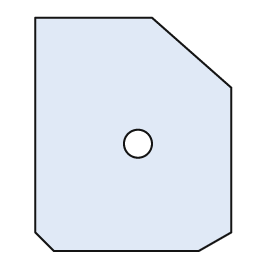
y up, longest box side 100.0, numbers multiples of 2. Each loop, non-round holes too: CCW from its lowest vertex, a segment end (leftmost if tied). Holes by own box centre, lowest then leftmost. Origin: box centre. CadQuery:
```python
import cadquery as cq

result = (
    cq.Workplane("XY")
    .moveTo(-34.0, -50.0)
    .lineTo(28.0, -50.0)
    .lineTo(42.0, -42.0)
    .lineTo(42.0, 20.0)
    .lineTo(8.0, 50.0)
    .lineTo(-42.0, 50.0)
    .lineTo(-42.0, -42.0)
    .close()
    .moveTo(2.0, -4.0)
    .circle(6.0)
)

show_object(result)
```